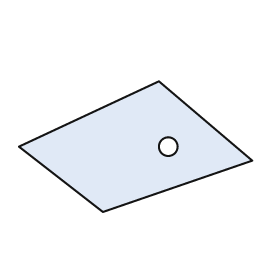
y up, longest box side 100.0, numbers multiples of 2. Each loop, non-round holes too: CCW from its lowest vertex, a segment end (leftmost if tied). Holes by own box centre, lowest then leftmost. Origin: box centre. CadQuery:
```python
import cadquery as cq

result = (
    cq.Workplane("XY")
    .moveTo(-14.0, -28.0)
    .lineTo(50.0, -6.0)
    .lineTo(10.0, 28.0)
    .lineTo(-50.0, 0.0)
    .close()
    .moveTo(14.0, 0.0)
    .circle(4.0)
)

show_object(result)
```